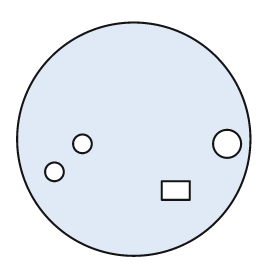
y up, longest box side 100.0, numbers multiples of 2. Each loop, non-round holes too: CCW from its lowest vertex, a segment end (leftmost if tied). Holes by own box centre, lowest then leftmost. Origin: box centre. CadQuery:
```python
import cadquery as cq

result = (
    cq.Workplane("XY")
    .moveTo(0.0, 0.0)
    .circle(50.0)
    .moveTo(12.0, -26.0)
    .lineTo(24.0, -26.0)
    .lineTo(24.0, -18.0)
    .lineTo(12.0, -18.0)
    .close()
    .moveTo(-34.0, -14.0)
    .circle(4.0)
    .moveTo(-22.0, -2.0)
    .circle(4.0)
    .moveTo(40.0, -2.0)
    .circle(6.0)
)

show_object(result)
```